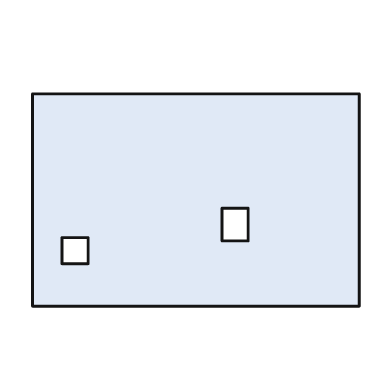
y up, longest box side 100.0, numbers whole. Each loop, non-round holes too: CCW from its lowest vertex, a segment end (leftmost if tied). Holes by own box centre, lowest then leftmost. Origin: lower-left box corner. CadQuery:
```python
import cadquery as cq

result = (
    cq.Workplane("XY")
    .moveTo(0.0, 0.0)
    .lineTo(100.0, 0.0)
    .lineTo(100.0, 65.0)
    .lineTo(0.0, 65.0)
    .close()
    .moveTo(9.0, 13.0)
    .lineTo(17.0, 13.0)
    .lineTo(17.0, 21.0)
    .lineTo(9.0, 21.0)
    .close()
    .moveTo(58.0, 20.0)
    .lineTo(66.0, 20.0)
    .lineTo(66.0, 30.0)
    .lineTo(58.0, 30.0)
    .close()
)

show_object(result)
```